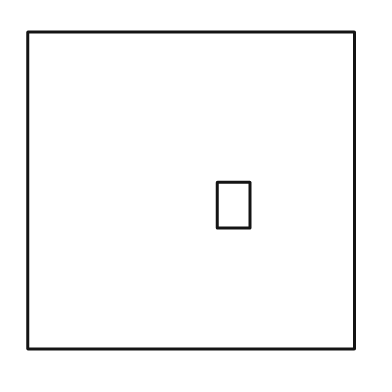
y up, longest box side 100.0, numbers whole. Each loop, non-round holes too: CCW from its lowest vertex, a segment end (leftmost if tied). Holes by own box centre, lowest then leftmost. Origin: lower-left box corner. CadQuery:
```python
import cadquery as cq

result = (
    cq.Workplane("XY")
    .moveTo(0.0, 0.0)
    .lineTo(100.0, 0.0)
    .lineTo(100.0, 97.0)
    .lineTo(0.0, 97.0)
    .close()
    .moveTo(58.0, 37.0)
    .lineTo(68.0, 37.0)
    .lineTo(68.0, 51.0)
    .lineTo(58.0, 51.0)
    .close()
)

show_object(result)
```